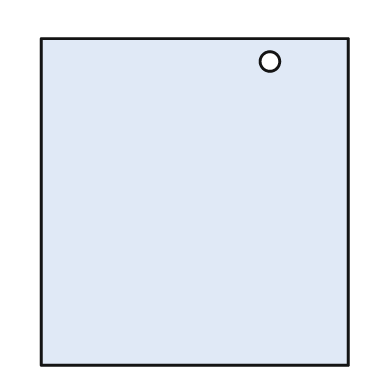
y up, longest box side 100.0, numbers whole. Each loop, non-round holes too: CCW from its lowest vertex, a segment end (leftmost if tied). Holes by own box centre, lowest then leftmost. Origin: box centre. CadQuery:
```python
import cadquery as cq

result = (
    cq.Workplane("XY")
    .moveTo(-47.0, -50.0)
    .lineTo(47.0, -50.0)
    .lineTo(47.0, 50.0)
    .lineTo(-47.0, 50.0)
    .close()
    .moveTo(23.0, 43.0)
    .circle(3.0)
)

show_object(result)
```